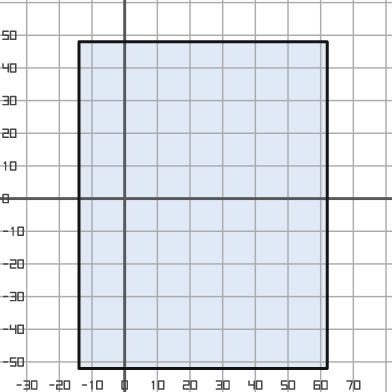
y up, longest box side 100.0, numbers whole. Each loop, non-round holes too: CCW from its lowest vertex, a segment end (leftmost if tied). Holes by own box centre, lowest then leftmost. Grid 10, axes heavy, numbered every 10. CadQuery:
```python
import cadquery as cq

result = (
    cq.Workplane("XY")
    .moveTo(-14.0, -52.0)
    .lineTo(62.0, -52.0)
    .lineTo(62.0, 48.0)
    .lineTo(-14.0, 48.0)
    .close()
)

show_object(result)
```